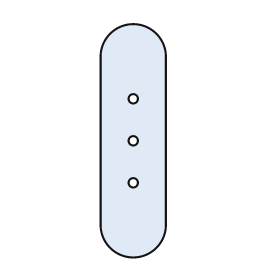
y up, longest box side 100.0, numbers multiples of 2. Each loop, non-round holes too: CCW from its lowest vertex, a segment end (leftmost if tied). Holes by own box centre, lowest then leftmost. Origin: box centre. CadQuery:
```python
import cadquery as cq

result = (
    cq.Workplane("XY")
    .moveTo(-14.0, -36.0)
    .threePointArc((0.0, -50.0), (14.0, -36.0))
    .lineTo(14.0, 36.0)
    .threePointArc((0.0, 50.0), (-14.0, 36.0))
    .close()
    .moveTo(0.0, -18.0)
    .circle(2.0)
    .moveTo(0.0, 0.0)
    .circle(2.0)
    .moveTo(0.0, 18.0)
    .circle(2.0)
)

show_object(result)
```